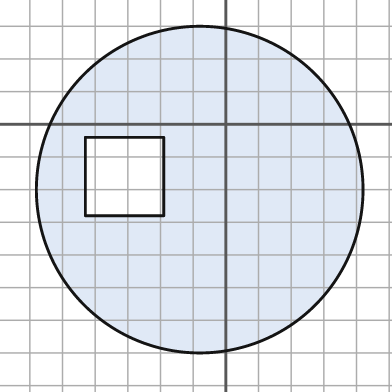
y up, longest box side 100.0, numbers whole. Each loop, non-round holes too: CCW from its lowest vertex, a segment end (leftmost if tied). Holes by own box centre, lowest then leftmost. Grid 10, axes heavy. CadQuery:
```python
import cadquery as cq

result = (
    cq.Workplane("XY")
    .moveTo(-8.0, -20.0)
    .circle(50.0)
    .moveTo(-43.0, -28.0)
    .lineTo(-19.0, -28.0)
    .lineTo(-19.0, -4.0)
    .lineTo(-43.0, -4.0)
    .close()
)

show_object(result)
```